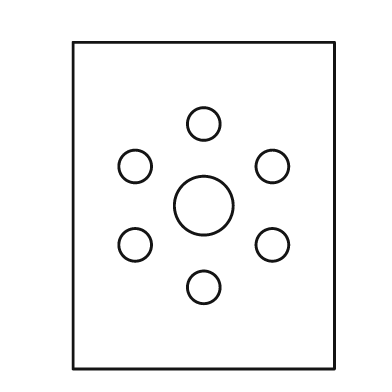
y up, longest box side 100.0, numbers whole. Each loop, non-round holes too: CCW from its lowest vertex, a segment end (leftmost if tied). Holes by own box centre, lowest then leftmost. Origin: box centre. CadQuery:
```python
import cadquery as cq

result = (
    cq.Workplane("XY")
    .moveTo(-40.0, -50.0)
    .lineTo(40.0, -50.0)
    .lineTo(40.0, 50.0)
    .lineTo(-40.0, 50.0)
    .close()
    .moveTo(0.0, -25.0)
    .circle(5.0)
    .moveTo(-21.0, -12.0)
    .circle(5.0)
    .moveTo(21.0, -12.0)
    .circle(5.0)
    .moveTo(0.0, 0.0)
    .circle(9.0)
    .moveTo(-21.0, 12.0)
    .circle(5.0)
    .moveTo(21.0, 12.0)
    .circle(5.0)
    .moveTo(0.0, 25.0)
    .circle(5.0)
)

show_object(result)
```